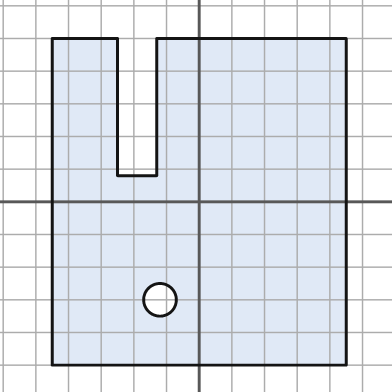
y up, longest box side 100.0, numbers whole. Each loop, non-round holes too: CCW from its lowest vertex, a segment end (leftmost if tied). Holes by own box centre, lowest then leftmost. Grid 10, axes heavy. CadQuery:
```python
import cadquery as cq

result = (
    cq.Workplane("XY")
    .moveTo(-45.0, -50.0)
    .lineTo(45.0, -50.0)
    .lineTo(45.0, 50.0)
    .lineTo(-13.0, 50.0)
    .lineTo(-13.0, 8.0)
    .lineTo(-25.0, 8.0)
    .lineTo(-25.0, 50.0)
    .lineTo(-45.0, 50.0)
    .close()
    .moveTo(-12.0, -30.0)
    .circle(5.0)
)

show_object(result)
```